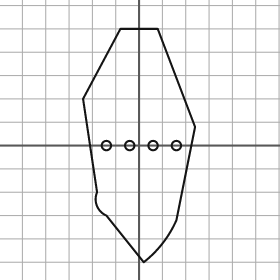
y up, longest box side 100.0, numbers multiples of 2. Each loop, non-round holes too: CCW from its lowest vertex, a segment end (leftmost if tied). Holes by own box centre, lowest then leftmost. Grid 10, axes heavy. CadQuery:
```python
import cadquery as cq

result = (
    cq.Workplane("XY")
    .moveTo(2.0, -50.0)
    .threePointArc((10.0, -42.0), (16.0, -32.0))
    .lineTo(24.0, 8.0)
    .lineTo(8.0, 50.0)
    .lineTo(-8.0, 50.0)
    .lineTo(-24.0, 20.0)
    .lineTo(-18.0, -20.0)
    .threePointArc((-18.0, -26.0), (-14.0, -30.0))
    .close()
    .moveTo(-14.0, 0.0)
    .circle(2.0)
    .moveTo(-4.0, 0.0)
    .circle(2.0)
    .moveTo(6.0, 0.0)
    .circle(2.0)
    .moveTo(16.0, 0.0)
    .circle(2.0)
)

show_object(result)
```